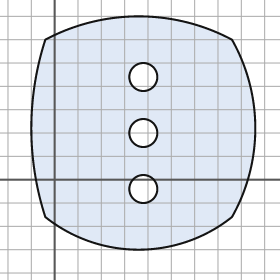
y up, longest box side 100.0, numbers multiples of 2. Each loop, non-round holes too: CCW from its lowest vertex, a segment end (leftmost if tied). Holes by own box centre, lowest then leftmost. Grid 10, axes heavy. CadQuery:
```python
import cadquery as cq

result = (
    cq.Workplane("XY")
    .moveTo(-4.0, -16.0)
    .threePointArc((36.0, -30.0), (76.0, -16.0))
    .threePointArc((86.0, 22.0), (76.0, 60.0))
    .threePointArc((36.0, 70.0), (-4.0, 60.0))
    .threePointArc((-10.0, 22.0), (-4.0, -16.0))
    .close()
    .moveTo(38.0, -4.0)
    .circle(6.0)
    .moveTo(38.0, 20.0)
    .circle(6.0)
    .moveTo(38.0, 44.0)
    .circle(6.0)
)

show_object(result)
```